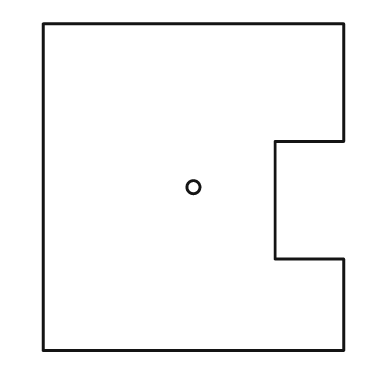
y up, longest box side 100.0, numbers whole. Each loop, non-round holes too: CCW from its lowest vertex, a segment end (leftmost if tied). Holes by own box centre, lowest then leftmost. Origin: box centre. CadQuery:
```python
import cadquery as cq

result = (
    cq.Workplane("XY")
    .moveTo(-46.0, -50.0)
    .lineTo(46.0, -50.0)
    .lineTo(46.0, -22.0)
    .lineTo(25.0, -22.0)
    .lineTo(25.0, 14.0)
    .lineTo(46.0, 14.0)
    .lineTo(46.0, 50.0)
    .lineTo(-46.0, 50.0)
    .close()
    .moveTo(0.0, 0.0)
    .circle(2.0)
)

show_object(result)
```